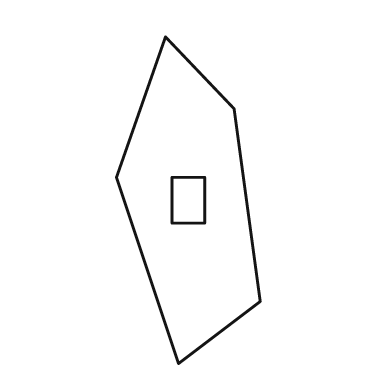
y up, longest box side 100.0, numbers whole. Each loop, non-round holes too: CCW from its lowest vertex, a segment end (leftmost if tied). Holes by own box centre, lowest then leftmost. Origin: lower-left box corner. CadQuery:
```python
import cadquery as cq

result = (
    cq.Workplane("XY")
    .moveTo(19.0, 0.0)
    .lineTo(44.0, 19.0)
    .lineTo(36.0, 78.0)
    .lineTo(15.0, 100.0)
    .lineTo(0.0, 57.0)
    .close()
    .moveTo(17.0, 43.0)
    .lineTo(27.0, 43.0)
    .lineTo(27.0, 57.0)
    .lineTo(17.0, 57.0)
    .close()
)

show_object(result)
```